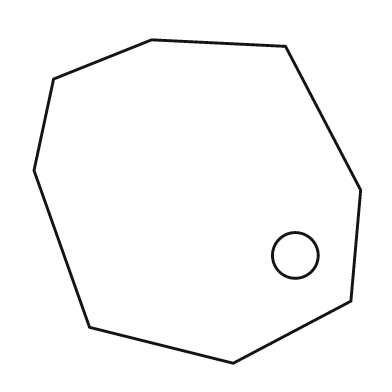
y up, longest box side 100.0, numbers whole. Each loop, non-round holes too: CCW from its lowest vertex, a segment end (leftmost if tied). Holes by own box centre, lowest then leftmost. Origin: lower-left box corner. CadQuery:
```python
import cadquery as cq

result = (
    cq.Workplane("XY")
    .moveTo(61.0, 0.0)
    .lineTo(97.0, 19.0)
    .lineTo(100.0, 53.0)
    .lineTo(77.0, 97.0)
    .lineTo(36.0, 99.0)
    .lineTo(6.0, 87.0)
    .lineTo(0.0, 59.0)
    .lineTo(17.0, 11.0)
    .close()
    .moveTo(80.0, 33.0)
    .circle(7.0)
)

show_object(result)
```